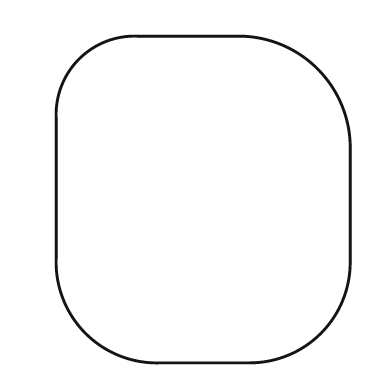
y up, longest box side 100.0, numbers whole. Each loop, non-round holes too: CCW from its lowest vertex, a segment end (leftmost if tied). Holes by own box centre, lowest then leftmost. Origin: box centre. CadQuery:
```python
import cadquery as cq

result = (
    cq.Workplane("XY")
    .moveTo(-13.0, -50.0)
    .lineTo(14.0, -50.0)
    .threePointArc((36.0, -41.0), (45.0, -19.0))
    .lineTo(45.0, 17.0)
    .threePointArc((35.0, 40.0), (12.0, 50.0))
    .lineTo(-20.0, 50.0)
    .threePointArc((-38.0, 43.0), (-45.0, 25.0))
    .lineTo(-45.0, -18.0)
    .threePointArc((-36.0, -41.0), (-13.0, -50.0))
    .close()
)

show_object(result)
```